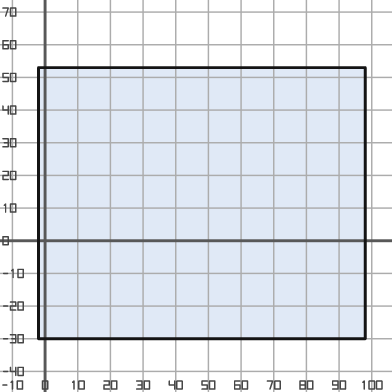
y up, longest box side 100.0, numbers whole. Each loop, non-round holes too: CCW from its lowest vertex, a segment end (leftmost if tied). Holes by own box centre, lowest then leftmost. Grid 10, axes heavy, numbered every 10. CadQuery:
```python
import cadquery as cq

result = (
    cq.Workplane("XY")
    .moveTo(-2.0, -30.0)
    .lineTo(98.0, -30.0)
    .lineTo(98.0, 53.0)
    .lineTo(-2.0, 53.0)
    .close()
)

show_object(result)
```